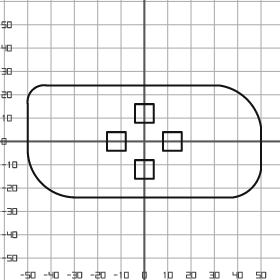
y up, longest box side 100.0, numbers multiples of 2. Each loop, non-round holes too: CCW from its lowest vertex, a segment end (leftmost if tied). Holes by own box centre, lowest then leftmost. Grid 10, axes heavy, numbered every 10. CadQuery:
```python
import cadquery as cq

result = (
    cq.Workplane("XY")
    .moveTo(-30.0, -24.0)
    .lineTo(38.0, -24.0)
    .threePointArc((46.0, -20.0), (50.0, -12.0))
    .lineTo(50.0, 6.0)
    .threePointArc((44.0, 18.0), (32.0, 24.0))
    .lineTo(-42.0, 24.0)
    .threePointArc((-48.0, 22.0), (-50.0, 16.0))
    .lineTo(-50.0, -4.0)
    .threePointArc((-44.0, -18.0), (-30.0, -24.0))
    .close()
    .moveTo(-4.0, -16.0)
    .lineTo(4.0, -16.0)
    .lineTo(4.0, -8.0)
    .lineTo(-4.0, -8.0)
    .close()
    .moveTo(-16.0, -4.0)
    .lineTo(-8.0, -4.0)
    .lineTo(-8.0, 4.0)
    .lineTo(-16.0, 4.0)
    .close()
    .moveTo(8.0, -4.0)
    .lineTo(16.0, -4.0)
    .lineTo(16.0, 4.0)
    .lineTo(8.0, 4.0)
    .close()
    .moveTo(-4.0, 8.0)
    .lineTo(4.0, 8.0)
    .lineTo(4.0, 16.0)
    .lineTo(-4.0, 16.0)
    .close()
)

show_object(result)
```